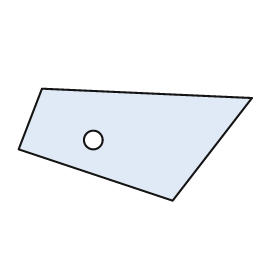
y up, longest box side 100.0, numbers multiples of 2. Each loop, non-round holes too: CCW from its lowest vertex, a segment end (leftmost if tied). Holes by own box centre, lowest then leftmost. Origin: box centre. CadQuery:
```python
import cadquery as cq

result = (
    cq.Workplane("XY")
    .moveTo(16.0, -24.0)
    .lineTo(50.0, 20.0)
    .lineTo(-40.0, 24.0)
    .lineTo(-50.0, -2.0)
    .close()
    .moveTo(-18.0, 2.0)
    .circle(4.0)
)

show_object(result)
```